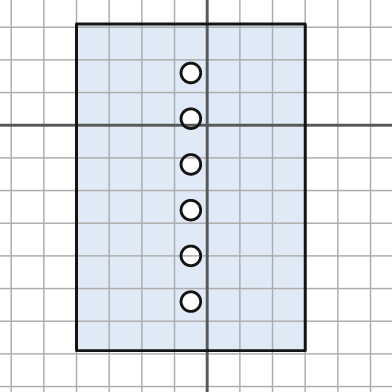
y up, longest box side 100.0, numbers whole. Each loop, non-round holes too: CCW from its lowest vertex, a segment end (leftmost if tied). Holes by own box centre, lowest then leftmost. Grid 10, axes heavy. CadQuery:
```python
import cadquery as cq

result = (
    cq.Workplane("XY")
    .moveTo(-40.0, -69.0)
    .lineTo(30.0, -69.0)
    .lineTo(30.0, 31.0)
    .lineTo(-40.0, 31.0)
    .close()
    .moveTo(-5.0, -54.0)
    .circle(3.0)
    .moveTo(-5.0, -40.0)
    .circle(3.0)
    .moveTo(-5.0, -26.0)
    .circle(3.0)
    .moveTo(-5.0, -12.0)
    .circle(3.0)
    .moveTo(-5.0, 2.0)
    .circle(3.0)
    .moveTo(-5.0, 16.0)
    .circle(3.0)
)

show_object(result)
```